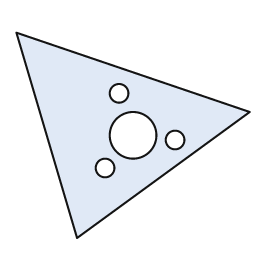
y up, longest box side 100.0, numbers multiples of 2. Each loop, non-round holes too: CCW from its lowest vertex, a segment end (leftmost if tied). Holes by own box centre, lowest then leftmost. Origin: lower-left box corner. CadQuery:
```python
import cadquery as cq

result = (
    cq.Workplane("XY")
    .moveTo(26.0, 0.0)
    .lineTo(100.0, 54.0)
    .lineTo(0.0, 88.0)
    .close()
    .moveTo(38.0, 30.0)
    .circle(4.0)
    .moveTo(68.0, 42.0)
    .circle(4.0)
    .moveTo(50.0, 44.0)
    .circle(10.0)
    .moveTo(44.0, 62.0)
    .circle(4.0)
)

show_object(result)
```